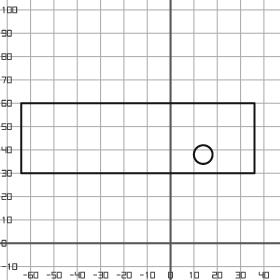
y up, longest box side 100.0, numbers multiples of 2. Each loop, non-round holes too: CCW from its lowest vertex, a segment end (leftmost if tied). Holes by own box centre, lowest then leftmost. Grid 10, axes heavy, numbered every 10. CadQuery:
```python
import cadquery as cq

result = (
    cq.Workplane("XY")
    .moveTo(-64.0, 30.0)
    .lineTo(36.0, 30.0)
    .lineTo(36.0, 60.0)
    .lineTo(-64.0, 60.0)
    .close()
    .moveTo(14.0, 38.0)
    .circle(4.0)
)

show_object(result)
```